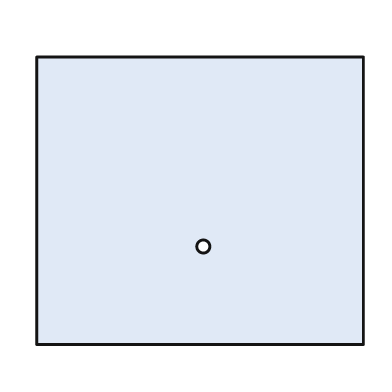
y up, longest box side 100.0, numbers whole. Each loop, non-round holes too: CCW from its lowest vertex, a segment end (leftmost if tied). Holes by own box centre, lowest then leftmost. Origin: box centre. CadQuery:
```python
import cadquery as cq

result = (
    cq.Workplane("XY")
    .moveTo(-50.0, -44.0)
    .lineTo(50.0, -44.0)
    .lineTo(50.0, 44.0)
    .lineTo(-50.0, 44.0)
    .close()
    .moveTo(1.0, -14.0)
    .circle(2.0)
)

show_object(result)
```